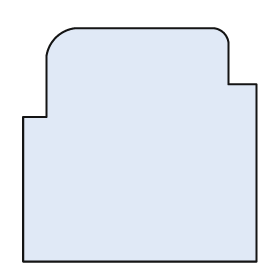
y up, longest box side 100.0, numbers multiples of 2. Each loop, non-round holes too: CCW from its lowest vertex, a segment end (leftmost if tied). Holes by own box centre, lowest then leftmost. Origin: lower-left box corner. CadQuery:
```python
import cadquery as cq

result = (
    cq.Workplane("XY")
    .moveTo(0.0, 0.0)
    .lineTo(100.0, 0.0)
    .lineTo(100.0, 76.0)
    .lineTo(88.0, 76.0)
    .lineTo(88.0, 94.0)
    .threePointArc((86.0, 98.0), (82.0, 100.0))
    .lineTo(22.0, 100.0)
    .threePointArc((14.0, 96.0), (10.0, 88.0))
    .lineTo(10.0, 62.0)
    .lineTo(0.0, 62.0)
    .close()
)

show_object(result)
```